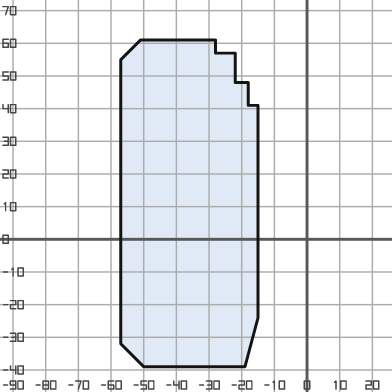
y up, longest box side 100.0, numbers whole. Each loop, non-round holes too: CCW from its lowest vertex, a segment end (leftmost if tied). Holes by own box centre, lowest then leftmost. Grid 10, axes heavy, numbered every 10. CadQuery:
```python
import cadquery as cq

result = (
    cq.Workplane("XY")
    .moveTo(-50.0, -39.0)
    .lineTo(-19.0, -39.0)
    .lineTo(-15.0, -24.0)
    .lineTo(-15.0, 41.0)
    .lineTo(-18.0, 41.0)
    .lineTo(-18.0, 48.0)
    .lineTo(-22.0, 48.0)
    .lineTo(-22.0, 57.0)
    .lineTo(-28.0, 57.0)
    .lineTo(-28.0, 61.0)
    .lineTo(-51.0, 61.0)
    .lineTo(-57.0, 55.0)
    .lineTo(-57.0, -32.0)
    .close()
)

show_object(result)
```